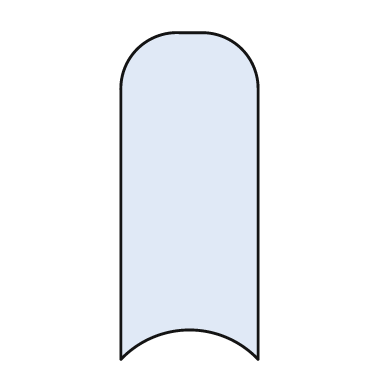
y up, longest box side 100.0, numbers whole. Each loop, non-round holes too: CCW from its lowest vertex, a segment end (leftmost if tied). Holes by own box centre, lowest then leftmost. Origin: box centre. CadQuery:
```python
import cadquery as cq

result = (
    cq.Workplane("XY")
    .moveTo(-21.0, -50.0)
    .threePointArc((0.0, -41.0), (21.0, -50.0))
    .lineTo(21.0, 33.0)
    .threePointArc((16.0, 45.0), (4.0, 50.0))
    .lineTo(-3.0, 50.0)
    .threePointArc((-16.0, 45.0), (-21.0, 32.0))
    .close()
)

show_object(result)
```